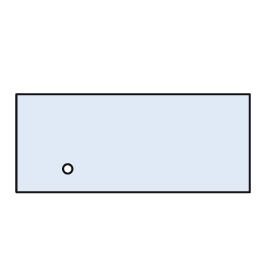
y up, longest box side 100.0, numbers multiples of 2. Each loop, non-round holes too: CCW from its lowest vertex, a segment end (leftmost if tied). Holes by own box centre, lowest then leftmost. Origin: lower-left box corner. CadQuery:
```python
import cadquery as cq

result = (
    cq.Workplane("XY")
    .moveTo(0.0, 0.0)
    .lineTo(100.0, 0.0)
    .lineTo(100.0, 42.0)
    .lineTo(0.0, 42.0)
    .close()
    .moveTo(22.0, 10.0)
    .circle(2.0)
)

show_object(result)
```